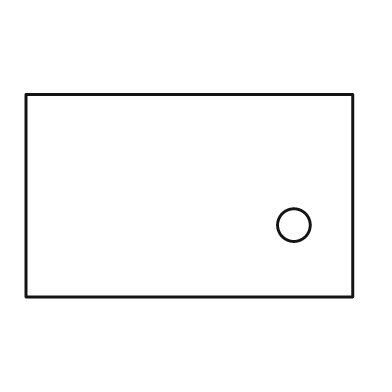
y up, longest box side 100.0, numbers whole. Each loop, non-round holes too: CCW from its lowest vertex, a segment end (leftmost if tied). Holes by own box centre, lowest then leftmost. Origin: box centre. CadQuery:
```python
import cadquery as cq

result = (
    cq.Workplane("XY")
    .moveTo(-50.0, -31.0)
    .lineTo(50.0, -31.0)
    .lineTo(50.0, 31.0)
    .lineTo(-50.0, 31.0)
    .close()
    .moveTo(32.0, -9.0)
    .circle(5.0)
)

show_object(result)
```